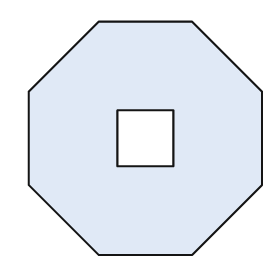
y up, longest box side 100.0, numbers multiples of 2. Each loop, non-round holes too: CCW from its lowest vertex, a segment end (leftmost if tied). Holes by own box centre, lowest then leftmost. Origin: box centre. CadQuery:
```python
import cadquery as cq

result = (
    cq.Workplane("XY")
    .moveTo(-20.0, -50.0)
    .lineTo(20.0, -50.0)
    .lineTo(50.0, -20.0)
    .lineTo(50.0, 20.0)
    .lineTo(20.0, 50.0)
    .lineTo(-20.0, 50.0)
    .lineTo(-50.0, 20.0)
    .lineTo(-50.0, -20.0)
    .close()
    .moveTo(-12.0, -12.0)
    .lineTo(12.0, -12.0)
    .lineTo(12.0, 12.0)
    .lineTo(-12.0, 12.0)
    .close()
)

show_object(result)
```